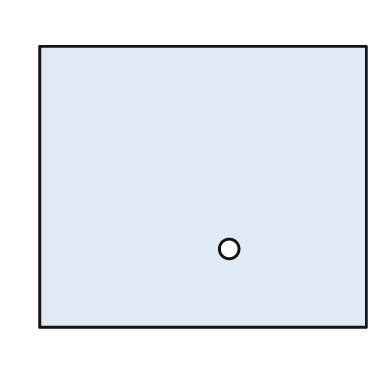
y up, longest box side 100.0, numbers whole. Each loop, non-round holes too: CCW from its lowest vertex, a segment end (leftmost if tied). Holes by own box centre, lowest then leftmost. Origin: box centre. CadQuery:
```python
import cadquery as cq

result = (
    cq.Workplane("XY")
    .moveTo(-50.0, -43.0)
    .lineTo(50.0, -43.0)
    .lineTo(50.0, 43.0)
    .lineTo(-50.0, 43.0)
    .close()
    .moveTo(8.0, -19.0)
    .circle(3.0)
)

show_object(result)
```